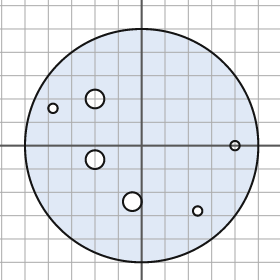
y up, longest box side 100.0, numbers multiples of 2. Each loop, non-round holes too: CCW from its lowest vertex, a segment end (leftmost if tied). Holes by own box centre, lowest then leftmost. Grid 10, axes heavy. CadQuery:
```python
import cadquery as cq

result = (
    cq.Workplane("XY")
    .moveTo(0.0, 0.0)
    .circle(50.0)
    .moveTo(24.0, -28.0)
    .circle(2.0)
    .moveTo(-4.0, -24.0)
    .circle(4.0)
    .moveTo(-20.0, -6.0)
    .circle(4.0)
    .moveTo(40.0, 0.0)
    .circle(2.0)
    .moveTo(-38.0, 16.0)
    .circle(2.0)
    .moveTo(-20.0, 20.0)
    .circle(4.0)
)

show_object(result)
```